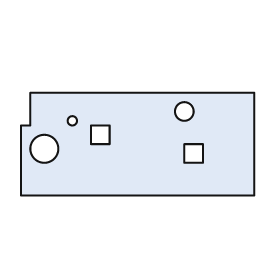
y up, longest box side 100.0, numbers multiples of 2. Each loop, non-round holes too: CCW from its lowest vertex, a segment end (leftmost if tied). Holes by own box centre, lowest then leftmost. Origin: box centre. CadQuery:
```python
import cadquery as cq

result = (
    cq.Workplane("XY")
    .moveTo(-50.0, -22.0)
    .lineTo(50.0, -22.0)
    .lineTo(50.0, 22.0)
    .lineTo(-46.0, 22.0)
    .lineTo(-46.0, 8.0)
    .lineTo(-50.0, 8.0)
    .close()
    .moveTo(20.0, -8.0)
    .lineTo(28.0, -8.0)
    .lineTo(28.0, 0.0)
    .lineTo(20.0, 0.0)
    .close()
    .moveTo(-40.0, -2.0)
    .circle(6.0)
    .moveTo(-20.0, 0.0)
    .lineTo(-12.0, 0.0)
    .lineTo(-12.0, 8.0)
    .lineTo(-20.0, 8.0)
    .close()
    .moveTo(-28.0, 10.0)
    .circle(2.0)
    .moveTo(20.0, 14.0)
    .circle(4.0)
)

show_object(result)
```